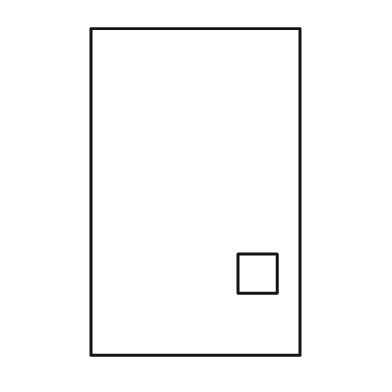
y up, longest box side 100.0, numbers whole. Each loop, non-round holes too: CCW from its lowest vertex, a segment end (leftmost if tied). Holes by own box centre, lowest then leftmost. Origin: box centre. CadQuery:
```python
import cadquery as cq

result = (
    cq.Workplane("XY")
    .moveTo(-32.0, -50.0)
    .lineTo(32.0, -50.0)
    .lineTo(32.0, 50.0)
    .lineTo(-32.0, 50.0)
    .close()
    .moveTo(13.0, -31.0)
    .lineTo(25.0, -31.0)
    .lineTo(25.0, -19.0)
    .lineTo(13.0, -19.0)
    .close()
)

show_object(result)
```